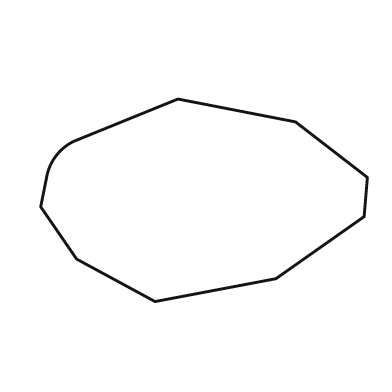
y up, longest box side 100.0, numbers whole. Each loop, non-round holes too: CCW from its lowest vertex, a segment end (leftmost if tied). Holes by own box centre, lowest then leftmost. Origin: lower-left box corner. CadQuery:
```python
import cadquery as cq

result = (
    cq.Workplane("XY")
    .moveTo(35.0, 0.0)
    .lineTo(72.0, 7.0)
    .lineTo(99.0, 26.0)
    .lineTo(100.0, 38.0)
    .lineTo(78.0, 55.0)
    .lineTo(42.0, 62.0)
    .lineTo(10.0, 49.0)
    .threePointArc((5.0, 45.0), (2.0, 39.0))
    .lineTo(0.0, 29.0)
    .lineTo(11.0, 13.0)
    .close()
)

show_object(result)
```